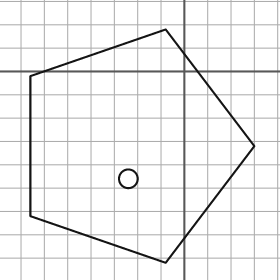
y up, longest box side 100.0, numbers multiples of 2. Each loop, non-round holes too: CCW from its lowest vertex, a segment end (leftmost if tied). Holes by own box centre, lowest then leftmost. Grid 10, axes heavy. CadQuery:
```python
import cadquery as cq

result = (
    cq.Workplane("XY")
    .moveTo(-8.0, -82.0)
    .lineTo(30.0, -32.0)
    .lineTo(-8.0, 18.0)
    .lineTo(-66.0, -2.0)
    .lineTo(-66.0, -62.0)
    .close()
    .moveTo(-24.0, -46.0)
    .circle(4.0)
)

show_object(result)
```